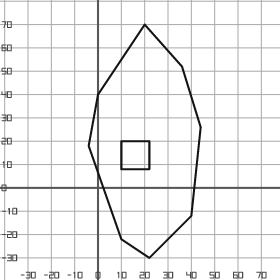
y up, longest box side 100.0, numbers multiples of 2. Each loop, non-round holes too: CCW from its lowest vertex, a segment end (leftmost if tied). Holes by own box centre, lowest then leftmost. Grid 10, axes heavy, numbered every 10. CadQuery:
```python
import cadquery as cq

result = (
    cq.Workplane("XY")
    .moveTo(22.0, -30.0)
    .lineTo(40.0, -12.0)
    .lineTo(44.0, 26.0)
    .lineTo(36.0, 52.0)
    .lineTo(20.0, 70.0)
    .lineTo(0.0, 40.0)
    .lineTo(-4.0, 18.0)
    .lineTo(10.0, -22.0)
    .close()
    .moveTo(10.0, 8.0)
    .lineTo(22.0, 8.0)
    .lineTo(22.0, 20.0)
    .lineTo(10.0, 20.0)
    .close()
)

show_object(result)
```